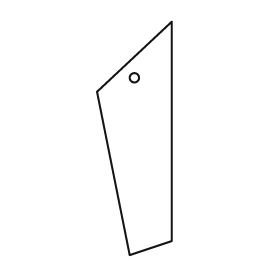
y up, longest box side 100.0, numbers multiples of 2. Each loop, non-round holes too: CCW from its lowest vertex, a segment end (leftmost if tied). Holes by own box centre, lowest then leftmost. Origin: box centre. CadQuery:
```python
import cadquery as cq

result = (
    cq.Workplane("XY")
    .moveTo(-2.0, -50.0)
    .lineTo(16.0, -44.0)
    .lineTo(16.0, 50.0)
    .lineTo(-16.0, 20.0)
    .close()
    .moveTo(0.0, 26.0)
    .circle(2.0)
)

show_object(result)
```